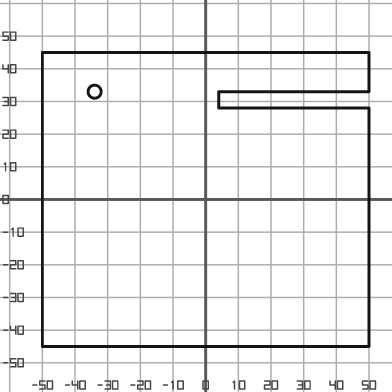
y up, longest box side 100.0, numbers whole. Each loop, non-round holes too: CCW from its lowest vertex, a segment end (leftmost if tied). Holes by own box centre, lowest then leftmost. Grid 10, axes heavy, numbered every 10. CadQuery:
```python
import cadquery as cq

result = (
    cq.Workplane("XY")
    .moveTo(-50.0, -45.0)
    .lineTo(50.0, -45.0)
    .lineTo(50.0, 28.0)
    .lineTo(4.0, 28.0)
    .lineTo(4.0, 33.0)
    .lineTo(50.0, 33.0)
    .lineTo(50.0, 45.0)
    .lineTo(-50.0, 45.0)
    .close()
    .moveTo(-34.0, 33.0)
    .circle(2.0)
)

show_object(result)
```